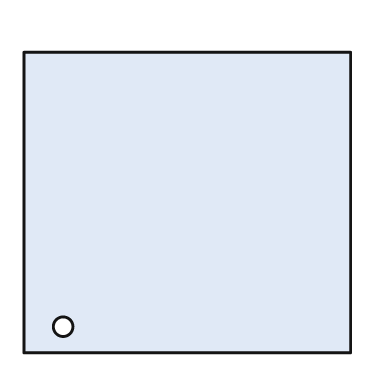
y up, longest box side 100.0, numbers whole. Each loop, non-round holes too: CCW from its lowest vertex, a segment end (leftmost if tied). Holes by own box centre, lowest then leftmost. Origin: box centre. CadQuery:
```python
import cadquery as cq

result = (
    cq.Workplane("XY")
    .moveTo(-50.0, -46.0)
    .lineTo(50.0, -46.0)
    .lineTo(50.0, 46.0)
    .lineTo(-50.0, 46.0)
    .close()
    .moveTo(-38.0, -38.0)
    .circle(3.0)
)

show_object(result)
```